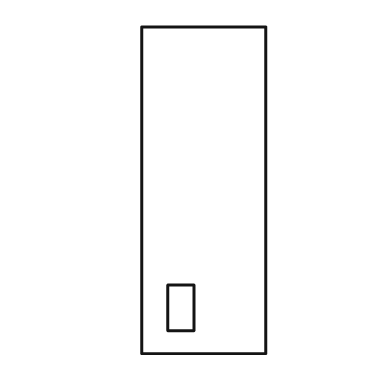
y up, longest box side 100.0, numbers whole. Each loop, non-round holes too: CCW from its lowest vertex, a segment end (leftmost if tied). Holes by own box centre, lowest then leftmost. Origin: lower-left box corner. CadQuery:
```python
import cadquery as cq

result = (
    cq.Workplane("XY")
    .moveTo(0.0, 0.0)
    .lineTo(38.0, 0.0)
    .lineTo(38.0, 100.0)
    .lineTo(0.0, 100.0)
    .close()
    .moveTo(8.0, 7.0)
    .lineTo(16.0, 7.0)
    .lineTo(16.0, 21.0)
    .lineTo(8.0, 21.0)
    .close()
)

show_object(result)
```